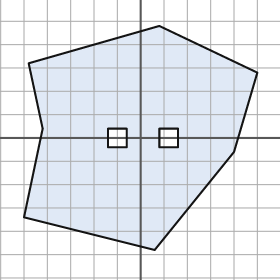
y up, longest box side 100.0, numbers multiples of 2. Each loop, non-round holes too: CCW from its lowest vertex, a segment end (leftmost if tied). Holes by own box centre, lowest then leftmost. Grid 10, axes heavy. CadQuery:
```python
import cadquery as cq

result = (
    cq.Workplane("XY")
    .moveTo(6.0, -48.0)
    .lineTo(40.0, -6.0)
    .lineTo(50.0, 28.0)
    .lineTo(8.0, 48.0)
    .lineTo(-48.0, 32.0)
    .lineTo(-42.0, 4.0)
    .lineTo(-50.0, -34.0)
    .close()
    .moveTo(-14.0, -4.0)
    .lineTo(-6.0, -4.0)
    .lineTo(-6.0, 4.0)
    .lineTo(-14.0, 4.0)
    .close()
    .moveTo(8.0, -4.0)
    .lineTo(16.0, -4.0)
    .lineTo(16.0, 4.0)
    .lineTo(8.0, 4.0)
    .close()
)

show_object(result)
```